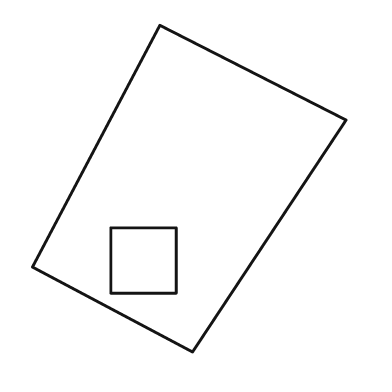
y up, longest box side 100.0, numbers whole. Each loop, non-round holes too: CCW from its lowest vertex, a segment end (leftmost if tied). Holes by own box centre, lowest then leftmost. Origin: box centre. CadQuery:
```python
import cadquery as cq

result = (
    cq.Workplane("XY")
    .moveTo(1.0, -50.0)
    .lineTo(48.0, 21.0)
    .lineTo(-9.0, 50.0)
    .lineTo(-48.0, -24.0)
    .close()
    .moveTo(-24.0, -32.0)
    .lineTo(-4.0, -32.0)
    .lineTo(-4.0, -12.0)
    .lineTo(-24.0, -12.0)
    .close()
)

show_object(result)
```